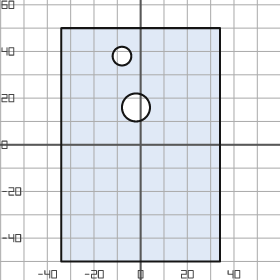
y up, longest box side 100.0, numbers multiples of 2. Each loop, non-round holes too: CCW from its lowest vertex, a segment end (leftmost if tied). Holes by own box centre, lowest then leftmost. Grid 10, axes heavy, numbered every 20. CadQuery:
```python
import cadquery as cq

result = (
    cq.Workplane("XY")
    .moveTo(-34.0, -50.0)
    .lineTo(34.0, -50.0)
    .lineTo(34.0, 50.0)
    .lineTo(-34.0, 50.0)
    .close()
    .moveTo(-2.0, 16.0)
    .circle(6.0)
    .moveTo(-8.0, 38.0)
    .circle(4.0)
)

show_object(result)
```